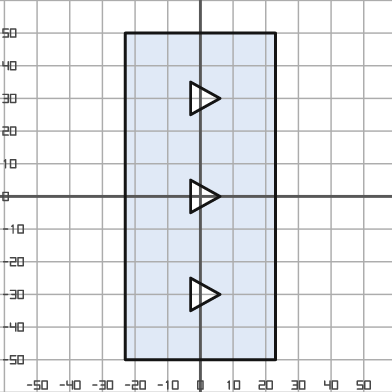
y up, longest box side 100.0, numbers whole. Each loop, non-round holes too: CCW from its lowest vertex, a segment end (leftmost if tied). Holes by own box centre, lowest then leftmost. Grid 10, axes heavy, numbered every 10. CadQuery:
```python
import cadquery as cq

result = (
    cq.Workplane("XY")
    .moveTo(-23.0, -50.0)
    .lineTo(23.0, -50.0)
    .lineTo(23.0, 50.0)
    .lineTo(-23.0, 50.0)
    .close()
    .moveTo(-3.0, -35.0)
    .lineTo(6.0, -30.0)
    .lineTo(-3.0, -25.0)
    .close()
    .moveTo(-3.0, -5.0)
    .lineTo(6.0, 0.0)
    .lineTo(-3.0, 5.0)
    .close()
    .moveTo(-3.0, 25.0)
    .lineTo(6.0, 30.0)
    .lineTo(-3.0, 35.0)
    .close()
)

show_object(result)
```